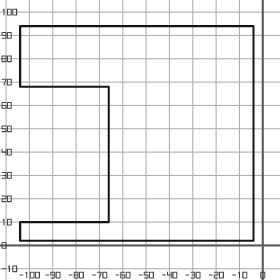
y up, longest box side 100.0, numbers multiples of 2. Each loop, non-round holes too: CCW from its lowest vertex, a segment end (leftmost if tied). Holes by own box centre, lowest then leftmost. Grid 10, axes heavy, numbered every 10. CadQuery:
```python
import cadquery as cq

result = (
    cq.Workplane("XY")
    .moveTo(-104.0, 2.0)
    .lineTo(-4.0, 2.0)
    .lineTo(-4.0, 94.0)
    .lineTo(-104.0, 94.0)
    .lineTo(-104.0, 68.0)
    .lineTo(-66.0, 68.0)
    .lineTo(-66.0, 10.0)
    .lineTo(-104.0, 10.0)
    .close()
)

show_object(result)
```